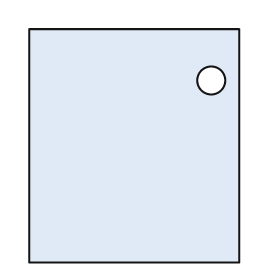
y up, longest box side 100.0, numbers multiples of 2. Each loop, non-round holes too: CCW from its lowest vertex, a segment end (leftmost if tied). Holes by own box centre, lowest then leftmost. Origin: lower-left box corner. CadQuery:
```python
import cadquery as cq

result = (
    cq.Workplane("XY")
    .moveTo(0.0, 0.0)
    .lineTo(90.0, 0.0)
    .lineTo(90.0, 100.0)
    .lineTo(0.0, 100.0)
    .close()
    .moveTo(78.0, 78.0)
    .circle(6.0)
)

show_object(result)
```